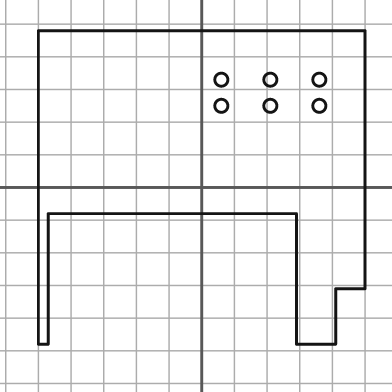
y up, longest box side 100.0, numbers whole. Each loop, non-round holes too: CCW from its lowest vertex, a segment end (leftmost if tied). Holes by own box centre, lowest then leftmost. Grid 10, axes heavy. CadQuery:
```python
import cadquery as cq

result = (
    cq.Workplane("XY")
    .moveTo(-50.0, -48.0)
    .lineTo(-47.0, -48.0)
    .lineTo(-47.0, -8.0)
    .lineTo(29.0, -8.0)
    .lineTo(29.0, -48.0)
    .lineTo(41.0, -48.0)
    .lineTo(41.0, -31.0)
    .lineTo(50.0, -31.0)
    .lineTo(50.0, 48.0)
    .lineTo(-50.0, 48.0)
    .close()
    .moveTo(6.0, 25.0)
    .circle(2.0)
    .moveTo(21.0, 25.0)
    .circle(2.0)
    .moveTo(36.0, 25.0)
    .circle(2.0)
    .moveTo(6.0, 33.0)
    .circle(2.0)
    .moveTo(21.0, 33.0)
    .circle(2.0)
    .moveTo(36.0, 33.0)
    .circle(2.0)
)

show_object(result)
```